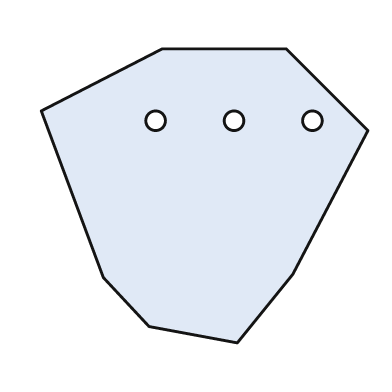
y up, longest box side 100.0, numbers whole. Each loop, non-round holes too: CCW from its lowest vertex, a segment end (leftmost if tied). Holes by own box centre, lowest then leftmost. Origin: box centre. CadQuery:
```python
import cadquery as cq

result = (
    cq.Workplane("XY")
    .moveTo(10.0, -45.0)
    .lineTo(27.0, -24.0)
    .lineTo(50.0, 20.0)
    .lineTo(25.0, 45.0)
    .lineTo(-13.0, 45.0)
    .lineTo(-50.0, 26.0)
    .lineTo(-31.0, -25.0)
    .lineTo(-17.0, -40.0)
    .close()
    .moveTo(-15.0, 23.0)
    .circle(3.0)
    .moveTo(9.0, 23.0)
    .circle(3.0)
    .moveTo(33.0, 23.0)
    .circle(3.0)
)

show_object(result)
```